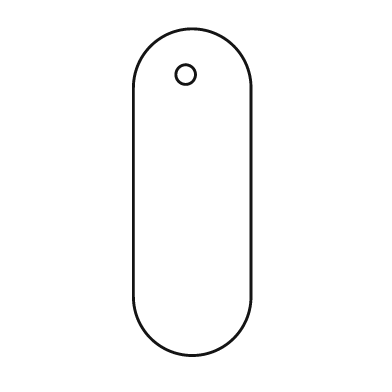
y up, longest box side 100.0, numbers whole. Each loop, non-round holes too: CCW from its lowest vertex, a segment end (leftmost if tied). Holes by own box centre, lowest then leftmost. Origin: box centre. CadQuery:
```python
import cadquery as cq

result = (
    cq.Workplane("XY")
    .moveTo(-18.0, -32.0)
    .threePointArc((0.0, -50.0), (18.0, -32.0))
    .lineTo(18.0, 32.0)
    .threePointArc((0.0, 50.0), (-18.0, 32.0))
    .close()
    .moveTo(-2.0, 36.0)
    .circle(3.0)
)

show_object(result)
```